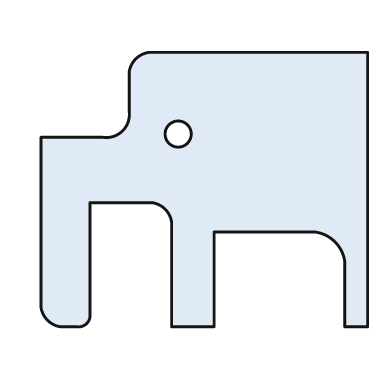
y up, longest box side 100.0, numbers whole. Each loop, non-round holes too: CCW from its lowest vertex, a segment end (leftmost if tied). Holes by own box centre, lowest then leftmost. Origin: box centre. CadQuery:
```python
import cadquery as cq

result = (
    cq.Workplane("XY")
    .moveTo(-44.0, -42.0)
    .lineTo(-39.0, -42.0)
    .threePointArc((-36.0, -41.0), (-35.0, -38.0))
    .lineTo(-35.0, -4.0)
    .lineTo(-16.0, -4.0)
    .threePointArc((-12.0, -6.0), (-10.0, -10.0))
    .lineTo(-10.0, -42.0)
    .lineTo(3.0, -42.0)
    .lineTo(3.0, -13.0)
    .lineTo(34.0, -13.0)
    .threePointArc((40.0, -16.0), (43.0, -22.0))
    .lineTo(43.0, -42.0)
    .lineTo(50.0, -42.0)
    .lineTo(50.0, 42.0)
    .lineTo(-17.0, 42.0)
    .threePointArc((-21.0, 40.0), (-23.0, 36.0))
    .lineTo(-23.0, 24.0)
    .threePointArc((-25.0, 18.0), (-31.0, 16.0))
    .lineTo(-50.0, 16.0)
    .lineTo(-50.0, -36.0)
    .threePointArc((-48.0, -40.0), (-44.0, -42.0))
    .close()
    .moveTo(-8.0, 17.0)
    .circle(4.0)
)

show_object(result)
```